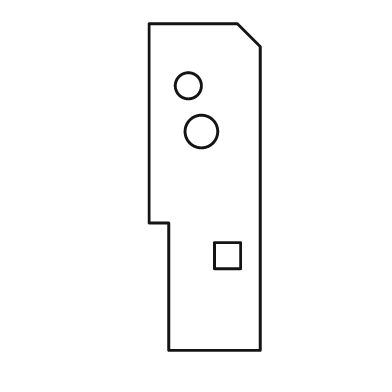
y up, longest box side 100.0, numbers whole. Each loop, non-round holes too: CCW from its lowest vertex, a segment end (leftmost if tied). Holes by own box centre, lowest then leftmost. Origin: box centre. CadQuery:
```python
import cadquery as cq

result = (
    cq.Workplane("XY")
    .moveTo(-11.0, -50.0)
    .lineTo(17.0, -50.0)
    .lineTo(17.0, 43.0)
    .lineTo(10.0, 50.0)
    .lineTo(-17.0, 50.0)
    .lineTo(-17.0, -11.0)
    .lineTo(-11.0, -11.0)
    .close()
    .moveTo(3.0, -25.0)
    .lineTo(11.0, -25.0)
    .lineTo(11.0, -17.0)
    .lineTo(3.0, -17.0)
    .close()
    .moveTo(-1.0, 17.0)
    .circle(5.0)
    .moveTo(-5.0, 31.0)
    .circle(4.0)
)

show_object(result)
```